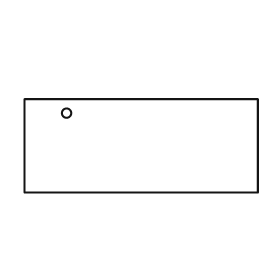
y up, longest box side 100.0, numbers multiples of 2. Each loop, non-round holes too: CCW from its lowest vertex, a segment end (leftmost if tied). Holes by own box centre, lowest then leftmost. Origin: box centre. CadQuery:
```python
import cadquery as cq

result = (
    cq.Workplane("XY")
    .moveTo(-50.0, -20.0)
    .lineTo(50.0, -20.0)
    .lineTo(50.0, 20.0)
    .lineTo(-50.0, 20.0)
    .close()
    .moveTo(-32.0, 14.0)
    .circle(2.0)
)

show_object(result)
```